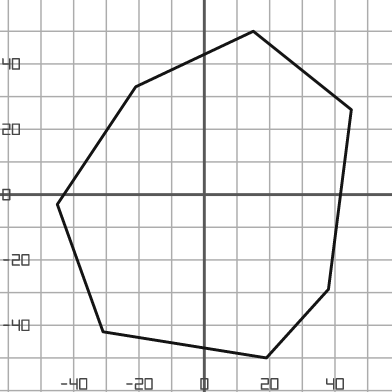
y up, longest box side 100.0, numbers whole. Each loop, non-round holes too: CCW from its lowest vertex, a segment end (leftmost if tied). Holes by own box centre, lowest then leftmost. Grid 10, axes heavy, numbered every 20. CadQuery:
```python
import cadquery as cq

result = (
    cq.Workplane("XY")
    .moveTo(19.0, -50.0)
    .lineTo(38.0, -29.0)
    .lineTo(45.0, 26.0)
    .lineTo(15.0, 50.0)
    .lineTo(-21.0, 33.0)
    .lineTo(-45.0, -3.0)
    .lineTo(-31.0, -42.0)
    .close()
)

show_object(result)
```